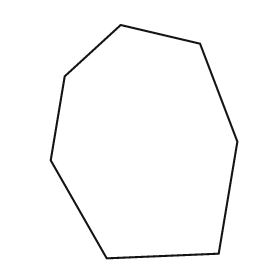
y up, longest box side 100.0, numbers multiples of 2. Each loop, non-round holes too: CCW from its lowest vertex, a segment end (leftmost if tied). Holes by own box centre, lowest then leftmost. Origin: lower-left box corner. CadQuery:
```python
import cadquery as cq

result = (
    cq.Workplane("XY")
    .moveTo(24.0, 0.0)
    .lineTo(72.0, 2.0)
    .lineTo(80.0, 50.0)
    .lineTo(64.0, 92.0)
    .lineTo(30.0, 100.0)
    .lineTo(6.0, 78.0)
    .lineTo(0.0, 42.0)
    .close()
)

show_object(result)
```